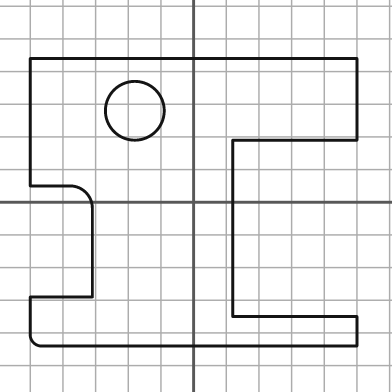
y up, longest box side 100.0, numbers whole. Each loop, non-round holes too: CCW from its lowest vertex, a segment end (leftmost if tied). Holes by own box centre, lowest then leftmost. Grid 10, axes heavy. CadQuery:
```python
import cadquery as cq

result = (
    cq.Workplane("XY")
    .moveTo(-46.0, -44.0)
    .lineTo(50.0, -44.0)
    .lineTo(50.0, -35.0)
    .lineTo(12.0, -35.0)
    .lineTo(12.0, 19.0)
    .lineTo(50.0, 19.0)
    .lineTo(50.0, 44.0)
    .lineTo(-50.0, 44.0)
    .lineTo(-50.0, 5.0)
    .lineTo(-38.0, 5.0)
    .threePointArc((-33.0, 3.0), (-31.0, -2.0))
    .lineTo(-31.0, -29.0)
    .lineTo(-50.0, -29.0)
    .lineTo(-50.0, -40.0)
    .threePointArc((-49.0, -43.0), (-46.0, -44.0))
    .close()
    .moveTo(-18.0, 28.0)
    .circle(9.0)
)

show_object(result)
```